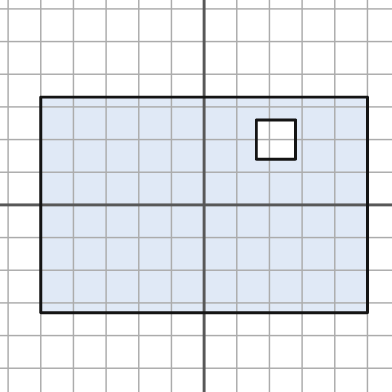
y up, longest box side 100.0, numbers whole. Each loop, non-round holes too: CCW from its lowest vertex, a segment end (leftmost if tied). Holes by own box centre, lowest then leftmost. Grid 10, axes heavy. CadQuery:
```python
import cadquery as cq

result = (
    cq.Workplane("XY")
    .moveTo(-50.0, -33.0)
    .lineTo(50.0, -33.0)
    .lineTo(50.0, 33.0)
    .lineTo(-50.0, 33.0)
    .close()
    .moveTo(16.0, 14.0)
    .lineTo(28.0, 14.0)
    .lineTo(28.0, 26.0)
    .lineTo(16.0, 26.0)
    .close()
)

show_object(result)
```